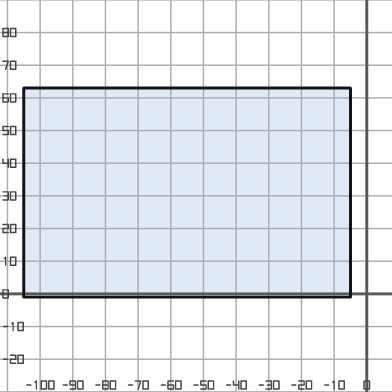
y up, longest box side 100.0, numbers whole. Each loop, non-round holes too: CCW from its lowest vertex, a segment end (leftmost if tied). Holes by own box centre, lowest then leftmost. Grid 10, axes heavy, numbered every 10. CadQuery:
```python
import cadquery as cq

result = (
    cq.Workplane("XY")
    .moveTo(-105.0, -1.0)
    .lineTo(-5.0, -1.0)
    .lineTo(-5.0, 63.0)
    .lineTo(-105.0, 63.0)
    .close()
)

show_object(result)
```